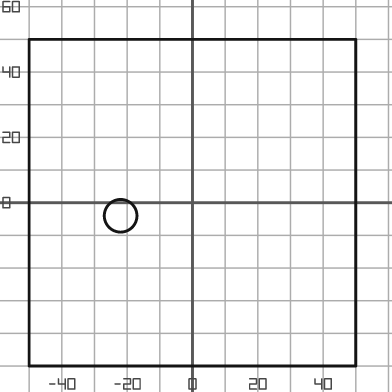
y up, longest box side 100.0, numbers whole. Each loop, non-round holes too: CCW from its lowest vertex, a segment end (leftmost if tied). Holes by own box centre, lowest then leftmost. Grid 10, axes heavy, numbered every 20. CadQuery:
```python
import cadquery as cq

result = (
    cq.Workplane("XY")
    .moveTo(-50.0, -50.0)
    .lineTo(50.0, -50.0)
    .lineTo(50.0, 50.0)
    .lineTo(-50.0, 50.0)
    .close()
    .moveTo(-22.0, -4.0)
    .circle(5.0)
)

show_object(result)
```